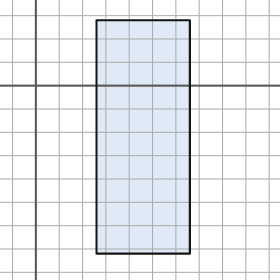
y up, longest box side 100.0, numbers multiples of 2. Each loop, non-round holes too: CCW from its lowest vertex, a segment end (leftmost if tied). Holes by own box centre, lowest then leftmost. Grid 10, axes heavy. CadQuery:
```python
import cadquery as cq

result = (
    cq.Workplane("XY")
    .moveTo(26.0, -72.0)
    .lineTo(66.0, -72.0)
    .lineTo(66.0, 28.0)
    .lineTo(26.0, 28.0)
    .close()
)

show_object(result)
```